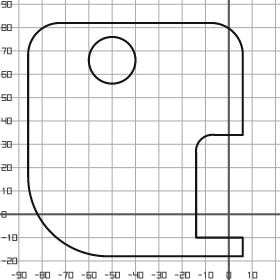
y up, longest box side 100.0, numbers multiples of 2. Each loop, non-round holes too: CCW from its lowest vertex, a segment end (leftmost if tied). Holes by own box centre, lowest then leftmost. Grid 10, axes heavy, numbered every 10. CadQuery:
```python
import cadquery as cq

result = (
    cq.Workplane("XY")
    .moveTo(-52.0, -18.0)
    .lineTo(6.0, -18.0)
    .lineTo(6.0, -10.0)
    .lineTo(-14.0, -10.0)
    .lineTo(-14.0, 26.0)
    .threePointArc((-12.0, 32.0), (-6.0, 34.0))
    .lineTo(6.0, 34.0)
    .lineTo(6.0, 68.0)
    .threePointArc((2.0, 78.0), (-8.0, 82.0))
    .lineTo(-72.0, 82.0)
    .threePointArc((-82.0, 78.0), (-86.0, 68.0))
    .lineTo(-86.0, 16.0)
    .threePointArc((-76.0, -8.0), (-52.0, -18.0))
    .close()
    .moveTo(-50.0, 66.0)
    .circle(10.0)
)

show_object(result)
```